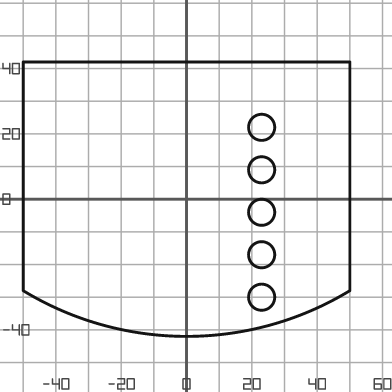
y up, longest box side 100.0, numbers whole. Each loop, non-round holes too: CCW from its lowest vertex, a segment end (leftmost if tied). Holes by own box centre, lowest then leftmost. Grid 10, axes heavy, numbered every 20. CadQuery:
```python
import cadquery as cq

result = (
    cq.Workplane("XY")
    .moveTo(-50.0, -28.0)
    .threePointArc((0.0, -42.0), (50.0, -28.0))
    .lineTo(50.0, 42.0)
    .lineTo(-50.0, 42.0)
    .close()
    .moveTo(23.0, -30.0)
    .circle(4.0)
    .moveTo(23.0, -17.0)
    .circle(4.0)
    .moveTo(23.0, -4.0)
    .circle(4.0)
    .moveTo(23.0, 9.0)
    .circle(4.0)
    .moveTo(23.0, 22.0)
    .circle(4.0)
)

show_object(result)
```